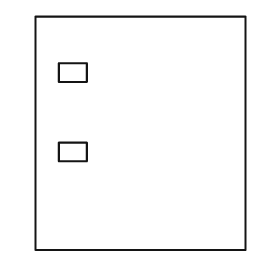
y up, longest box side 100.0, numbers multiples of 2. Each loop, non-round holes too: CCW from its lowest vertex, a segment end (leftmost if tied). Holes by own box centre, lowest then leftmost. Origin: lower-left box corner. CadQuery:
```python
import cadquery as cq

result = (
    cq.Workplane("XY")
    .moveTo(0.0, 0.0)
    .lineTo(90.0, 0.0)
    .lineTo(90.0, 100.0)
    .lineTo(0.0, 100.0)
    .close()
    .moveTo(10.0, 38.0)
    .lineTo(22.0, 38.0)
    .lineTo(22.0, 46.0)
    .lineTo(10.0, 46.0)
    .close()
    .moveTo(10.0, 72.0)
    .lineTo(22.0, 72.0)
    .lineTo(22.0, 80.0)
    .lineTo(10.0, 80.0)
    .close()
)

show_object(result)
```